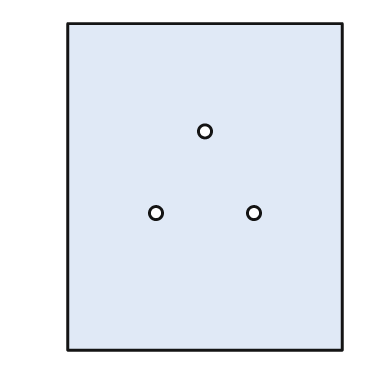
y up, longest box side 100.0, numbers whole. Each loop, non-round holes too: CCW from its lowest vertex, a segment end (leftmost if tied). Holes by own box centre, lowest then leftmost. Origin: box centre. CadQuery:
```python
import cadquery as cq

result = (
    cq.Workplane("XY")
    .moveTo(-42.0, -50.0)
    .lineTo(42.0, -50.0)
    .lineTo(42.0, 50.0)
    .lineTo(-42.0, 50.0)
    .close()
    .moveTo(-15.0, -8.0)
    .circle(2.0)
    .moveTo(15.0, -8.0)
    .circle(2.0)
    .moveTo(0.0, 17.0)
    .circle(2.0)
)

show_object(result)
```